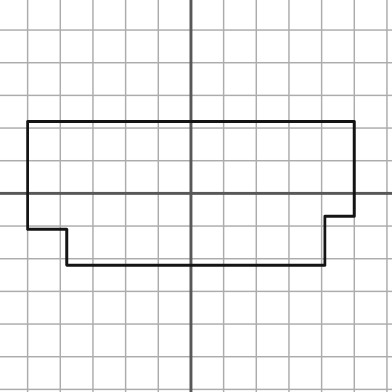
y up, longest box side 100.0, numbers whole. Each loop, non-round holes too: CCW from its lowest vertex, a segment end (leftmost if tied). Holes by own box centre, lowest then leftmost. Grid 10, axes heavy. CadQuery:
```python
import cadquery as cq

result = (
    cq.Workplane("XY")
    .moveTo(-38.0, -22.0)
    .lineTo(41.0, -22.0)
    .lineTo(41.0, -7.0)
    .lineTo(50.0, -7.0)
    .lineTo(50.0, 22.0)
    .lineTo(-50.0, 22.0)
    .lineTo(-50.0, -11.0)
    .lineTo(-38.0, -11.0)
    .close()
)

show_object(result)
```